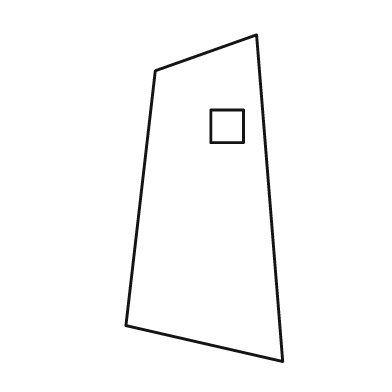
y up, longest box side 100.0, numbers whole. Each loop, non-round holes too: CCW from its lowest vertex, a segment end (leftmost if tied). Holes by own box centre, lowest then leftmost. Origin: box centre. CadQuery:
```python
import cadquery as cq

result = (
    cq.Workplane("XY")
    .moveTo(24.0, -50.0)
    .lineTo(16.0, 50.0)
    .lineTo(-15.0, 39.0)
    .lineTo(-24.0, -39.0)
    .close()
    .moveTo(2.0, 17.0)
    .lineTo(12.0, 17.0)
    .lineTo(12.0, 27.0)
    .lineTo(2.0, 27.0)
    .close()
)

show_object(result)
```